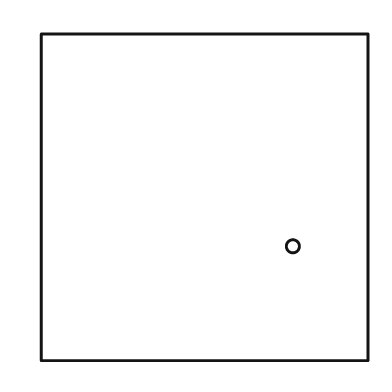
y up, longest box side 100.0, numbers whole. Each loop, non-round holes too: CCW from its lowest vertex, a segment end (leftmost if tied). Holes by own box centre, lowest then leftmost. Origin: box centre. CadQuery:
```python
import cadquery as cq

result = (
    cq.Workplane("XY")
    .moveTo(-50.0, -50.0)
    .lineTo(50.0, -50.0)
    .lineTo(50.0, 50.0)
    .lineTo(-50.0, 50.0)
    .close()
    .moveTo(27.0, -15.0)
    .circle(2.0)
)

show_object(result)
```